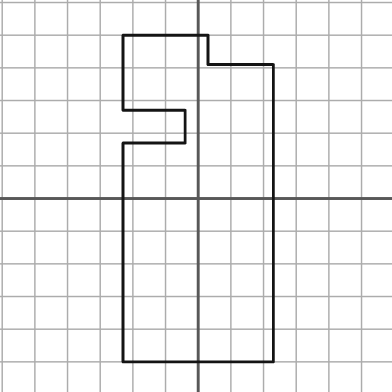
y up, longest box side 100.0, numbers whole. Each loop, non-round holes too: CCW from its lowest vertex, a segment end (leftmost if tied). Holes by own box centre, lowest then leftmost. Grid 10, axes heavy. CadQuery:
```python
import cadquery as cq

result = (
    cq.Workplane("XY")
    .moveTo(-23.0, -50.0)
    .lineTo(23.0, -50.0)
    .lineTo(23.0, 41.0)
    .lineTo(3.0, 41.0)
    .lineTo(3.0, 50.0)
    .lineTo(-23.0, 50.0)
    .lineTo(-23.0, 27.0)
    .lineTo(-4.0, 27.0)
    .lineTo(-4.0, 17.0)
    .lineTo(-23.0, 17.0)
    .close()
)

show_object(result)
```